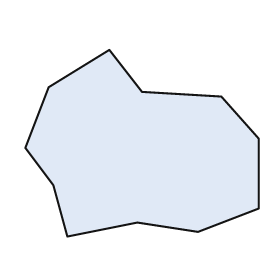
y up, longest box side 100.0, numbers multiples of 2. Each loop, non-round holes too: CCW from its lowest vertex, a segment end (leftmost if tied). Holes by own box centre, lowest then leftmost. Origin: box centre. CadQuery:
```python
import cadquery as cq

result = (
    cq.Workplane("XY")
    .moveTo(-32.0, -40.0)
    .lineTo(-2.0, -34.0)
    .lineTo(24.0, -38.0)
    .lineTo(50.0, -28.0)
    .lineTo(50.0, 2.0)
    .lineTo(34.0, 20.0)
    .lineTo(0.0, 22.0)
    .lineTo(-14.0, 40.0)
    .lineTo(-40.0, 24.0)
    .lineTo(-50.0, -2.0)
    .lineTo(-38.0, -18.0)
    .close()
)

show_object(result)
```